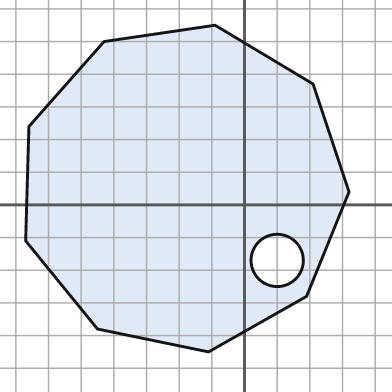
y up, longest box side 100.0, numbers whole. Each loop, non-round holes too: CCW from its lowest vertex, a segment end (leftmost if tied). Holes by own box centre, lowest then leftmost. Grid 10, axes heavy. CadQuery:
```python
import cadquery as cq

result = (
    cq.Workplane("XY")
    .moveTo(-11.0, -45.0)
    .lineTo(19.0, -28.0)
    .lineTo(32.0, 4.0)
    .lineTo(21.0, 37.0)
    .lineTo(-9.0, 55.0)
    .lineTo(-43.0, 50.0)
    .lineTo(-66.0, 24.0)
    .lineTo(-67.0, -11.0)
    .lineTo(-45.0, -38.0)
    .close()
    .moveTo(10.0, -17.0)
    .circle(8.0)
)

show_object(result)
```